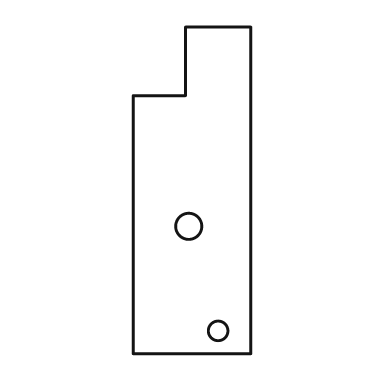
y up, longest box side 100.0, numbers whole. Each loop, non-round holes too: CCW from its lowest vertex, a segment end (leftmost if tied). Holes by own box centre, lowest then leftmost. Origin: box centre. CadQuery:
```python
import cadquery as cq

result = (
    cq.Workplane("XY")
    .moveTo(-18.0, -50.0)
    .lineTo(18.0, -50.0)
    .lineTo(18.0, 50.0)
    .lineTo(-2.0, 50.0)
    .lineTo(-2.0, 29.0)
    .lineTo(-18.0, 29.0)
    .close()
    .moveTo(8.0, -43.0)
    .circle(3.0)
    .moveTo(-1.0, -11.0)
    .circle(4.0)
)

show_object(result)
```